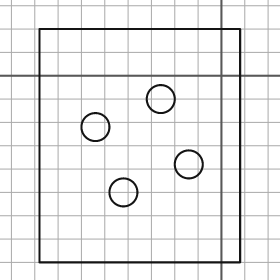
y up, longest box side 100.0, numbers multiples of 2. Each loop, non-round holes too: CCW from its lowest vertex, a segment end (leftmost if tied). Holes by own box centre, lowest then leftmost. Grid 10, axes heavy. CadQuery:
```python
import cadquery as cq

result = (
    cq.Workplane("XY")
    .moveTo(-78.0, -80.0)
    .lineTo(8.0, -80.0)
    .lineTo(8.0, 20.0)
    .lineTo(-78.0, 20.0)
    .close()
    .moveTo(-42.0, -50.0)
    .circle(6.0)
    .moveTo(-14.0, -38.0)
    .circle(6.0)
    .moveTo(-54.0, -22.0)
    .circle(6.0)
    .moveTo(-26.0, -10.0)
    .circle(6.0)
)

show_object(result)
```